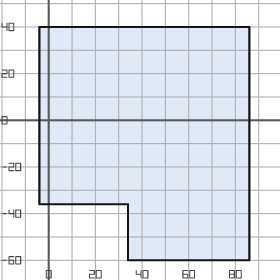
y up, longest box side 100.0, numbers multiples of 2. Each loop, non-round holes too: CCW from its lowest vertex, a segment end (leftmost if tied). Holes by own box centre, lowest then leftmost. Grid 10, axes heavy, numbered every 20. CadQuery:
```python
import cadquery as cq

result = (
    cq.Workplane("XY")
    .moveTo(34.0, -60.0)
    .lineTo(86.0, -60.0)
    .lineTo(86.0, 40.0)
    .lineTo(-4.0, 40.0)
    .lineTo(-4.0, -36.0)
    .lineTo(34.0, -36.0)
    .close()
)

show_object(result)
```